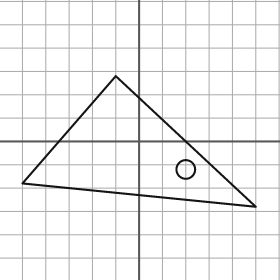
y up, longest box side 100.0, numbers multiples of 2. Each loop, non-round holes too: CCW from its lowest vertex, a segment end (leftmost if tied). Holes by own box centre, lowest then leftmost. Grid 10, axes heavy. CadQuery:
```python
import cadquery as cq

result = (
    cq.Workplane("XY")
    .moveTo(50.0, -28.0)
    .lineTo(-10.0, 28.0)
    .lineTo(-50.0, -18.0)
    .close()
    .moveTo(20.0, -12.0)
    .circle(4.0)
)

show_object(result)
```